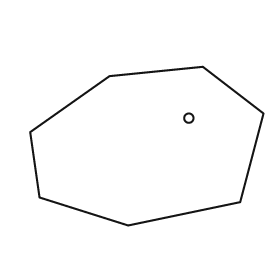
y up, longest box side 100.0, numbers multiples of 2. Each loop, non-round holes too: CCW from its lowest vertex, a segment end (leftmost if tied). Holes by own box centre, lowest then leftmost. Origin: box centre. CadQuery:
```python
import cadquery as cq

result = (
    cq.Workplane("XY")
    .moveTo(-8.0, -34.0)
    .lineTo(40.0, -24.0)
    .lineTo(50.0, 14.0)
    .lineTo(24.0, 34.0)
    .lineTo(-16.0, 30.0)
    .lineTo(-50.0, 6.0)
    .lineTo(-46.0, -22.0)
    .close()
    .moveTo(18.0, 12.0)
    .circle(2.0)
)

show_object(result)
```